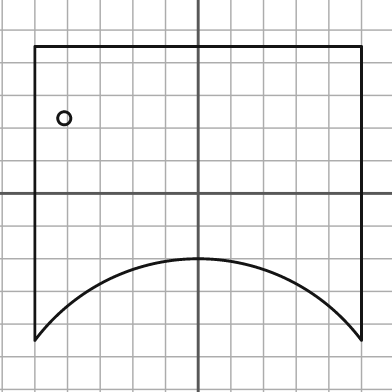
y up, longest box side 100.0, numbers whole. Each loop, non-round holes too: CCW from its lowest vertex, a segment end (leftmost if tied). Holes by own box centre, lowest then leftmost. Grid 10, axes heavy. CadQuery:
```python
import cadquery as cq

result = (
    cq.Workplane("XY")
    .moveTo(-50.0, -45.0)
    .threePointArc((0.0, -20.0), (50.0, -45.0))
    .lineTo(50.0, 45.0)
    .lineTo(-50.0, 45.0)
    .close()
    .moveTo(-41.0, 23.0)
    .circle(2.0)
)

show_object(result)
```